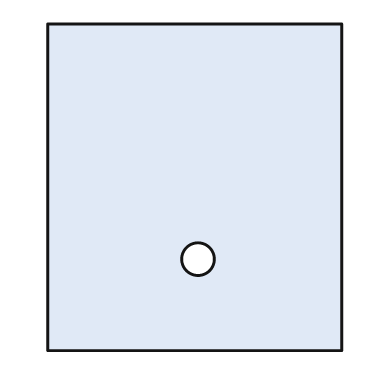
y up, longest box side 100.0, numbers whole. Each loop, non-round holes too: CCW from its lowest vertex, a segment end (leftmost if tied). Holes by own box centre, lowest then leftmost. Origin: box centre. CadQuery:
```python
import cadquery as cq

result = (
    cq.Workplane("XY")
    .moveTo(-45.0, -50.0)
    .lineTo(45.0, -50.0)
    .lineTo(45.0, 50.0)
    .lineTo(-45.0, 50.0)
    .close()
    .moveTo(1.0, -22.0)
    .circle(5.0)
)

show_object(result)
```